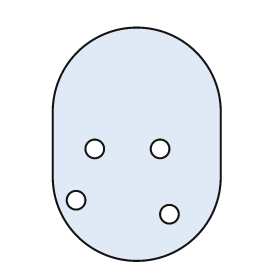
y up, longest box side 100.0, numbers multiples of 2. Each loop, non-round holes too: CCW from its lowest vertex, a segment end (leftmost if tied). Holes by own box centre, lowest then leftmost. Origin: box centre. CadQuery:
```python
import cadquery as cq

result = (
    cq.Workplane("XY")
    .moveTo(-36.0, -14.0)
    .threePointArc((0.0, -50.0), (36.0, -14.0))
    .lineTo(36.0, 14.0)
    .threePointArc((0.0, 50.0), (-36.0, 14.0))
    .close()
    .moveTo(14.0, -30.0)
    .circle(4.0)
    .moveTo(-26.0, -24.0)
    .circle(4.0)
    .moveTo(-18.0, -2.0)
    .circle(4.0)
    .moveTo(10.0, -2.0)
    .circle(4.0)
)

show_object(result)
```